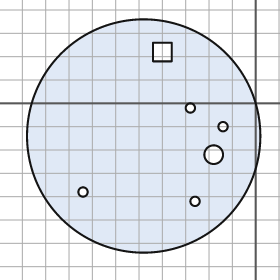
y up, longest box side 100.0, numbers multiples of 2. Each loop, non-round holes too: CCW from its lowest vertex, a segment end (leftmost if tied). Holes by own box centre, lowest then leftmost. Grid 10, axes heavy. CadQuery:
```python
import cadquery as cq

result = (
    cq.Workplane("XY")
    .moveTo(-48.0, -14.0)
    .circle(50.0)
    .moveTo(-26.0, -42.0)
    .circle(2.0)
    .moveTo(-74.0, -38.0)
    .circle(2.0)
    .moveTo(-18.0, -22.0)
    .circle(4.0)
    .moveTo(-14.0, -10.0)
    .circle(2.0)
    .moveTo(-28.0, -2.0)
    .circle(2.0)
    .moveTo(-44.0, 18.0)
    .lineTo(-36.0, 18.0)
    .lineTo(-36.0, 26.0)
    .lineTo(-44.0, 26.0)
    .close()
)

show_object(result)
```